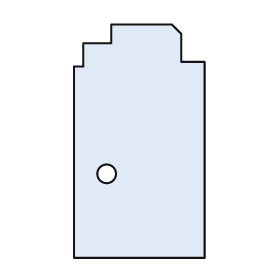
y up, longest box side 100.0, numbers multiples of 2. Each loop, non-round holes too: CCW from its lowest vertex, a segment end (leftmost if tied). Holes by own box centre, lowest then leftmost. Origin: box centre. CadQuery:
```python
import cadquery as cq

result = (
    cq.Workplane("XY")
    .moveTo(-28.0, -50.0)
    .lineTo(28.0, -50.0)
    .lineTo(28.0, 34.0)
    .lineTo(18.0, 34.0)
    .lineTo(18.0, 46.0)
    .lineTo(14.0, 50.0)
    .lineTo(-12.0, 50.0)
    .lineTo(-12.0, 42.0)
    .lineTo(-24.0, 42.0)
    .lineTo(-24.0, 32.0)
    .lineTo(-28.0, 32.0)
    .close()
    .moveTo(-14.0, -14.0)
    .circle(4.0)
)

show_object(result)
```